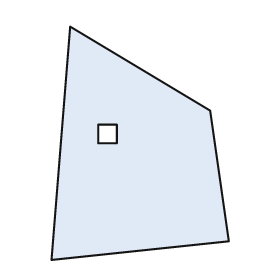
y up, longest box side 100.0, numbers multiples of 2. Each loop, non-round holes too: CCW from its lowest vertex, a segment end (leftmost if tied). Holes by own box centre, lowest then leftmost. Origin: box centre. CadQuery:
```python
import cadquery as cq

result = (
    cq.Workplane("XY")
    .moveTo(-38.0, -50.0)
    .lineTo(38.0, -42.0)
    .lineTo(30.0, 14.0)
    .lineTo(-30.0, 50.0)
    .close()
    .moveTo(-18.0, 0.0)
    .lineTo(-10.0, 0.0)
    .lineTo(-10.0, 8.0)
    .lineTo(-18.0, 8.0)
    .close()
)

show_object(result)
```